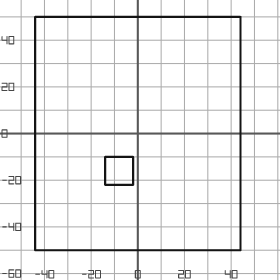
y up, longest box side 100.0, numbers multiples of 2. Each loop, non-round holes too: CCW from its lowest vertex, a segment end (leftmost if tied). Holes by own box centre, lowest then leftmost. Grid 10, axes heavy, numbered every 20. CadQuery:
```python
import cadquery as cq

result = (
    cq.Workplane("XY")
    .moveTo(-44.0, -50.0)
    .lineTo(44.0, -50.0)
    .lineTo(44.0, 50.0)
    .lineTo(-44.0, 50.0)
    .close()
    .moveTo(-14.0, -22.0)
    .lineTo(-2.0, -22.0)
    .lineTo(-2.0, -10.0)
    .lineTo(-14.0, -10.0)
    .close()
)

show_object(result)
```